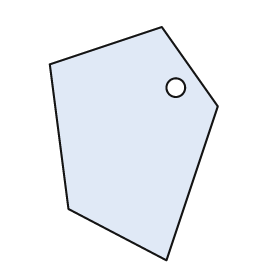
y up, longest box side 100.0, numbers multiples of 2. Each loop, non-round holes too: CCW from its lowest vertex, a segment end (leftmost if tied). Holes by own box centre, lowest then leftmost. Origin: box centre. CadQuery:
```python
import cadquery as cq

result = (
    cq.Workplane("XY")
    .moveTo(14.0, -50.0)
    .lineTo(36.0, 16.0)
    .lineTo(12.0, 50.0)
    .lineTo(-36.0, 34.0)
    .lineTo(-28.0, -28.0)
    .close()
    .moveTo(18.0, 24.0)
    .circle(4.0)
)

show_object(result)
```